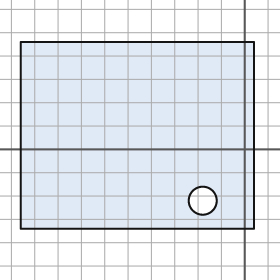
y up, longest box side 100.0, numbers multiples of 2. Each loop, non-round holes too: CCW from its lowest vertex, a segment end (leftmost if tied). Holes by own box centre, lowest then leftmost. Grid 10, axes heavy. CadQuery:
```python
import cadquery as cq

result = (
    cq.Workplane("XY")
    .moveTo(-96.0, -34.0)
    .lineTo(4.0, -34.0)
    .lineTo(4.0, 46.0)
    .lineTo(-96.0, 46.0)
    .close()
    .moveTo(-18.0, -22.0)
    .circle(6.0)
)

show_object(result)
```